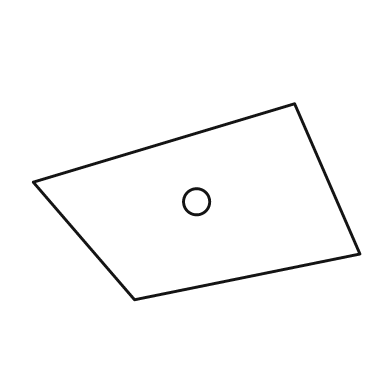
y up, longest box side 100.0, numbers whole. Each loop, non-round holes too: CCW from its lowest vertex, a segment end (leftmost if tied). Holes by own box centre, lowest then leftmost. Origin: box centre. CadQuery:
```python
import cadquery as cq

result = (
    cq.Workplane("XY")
    .moveTo(-19.0, -30.0)
    .lineTo(50.0, -16.0)
    .lineTo(30.0, 30.0)
    .lineTo(-50.0, 6.0)
    .close()
    .moveTo(0.0, 0.0)
    .circle(4.0)
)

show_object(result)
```